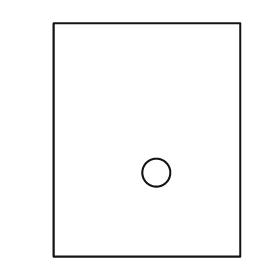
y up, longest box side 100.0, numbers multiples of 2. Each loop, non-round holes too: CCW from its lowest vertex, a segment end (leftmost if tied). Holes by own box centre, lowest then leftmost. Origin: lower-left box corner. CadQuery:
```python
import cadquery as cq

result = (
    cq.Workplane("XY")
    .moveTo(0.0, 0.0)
    .lineTo(80.0, 0.0)
    .lineTo(80.0, 100.0)
    .lineTo(0.0, 100.0)
    .close()
    .moveTo(44.0, 36.0)
    .circle(6.0)
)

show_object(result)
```